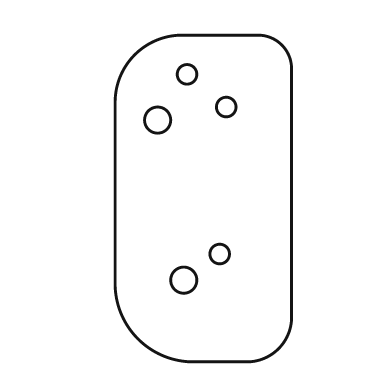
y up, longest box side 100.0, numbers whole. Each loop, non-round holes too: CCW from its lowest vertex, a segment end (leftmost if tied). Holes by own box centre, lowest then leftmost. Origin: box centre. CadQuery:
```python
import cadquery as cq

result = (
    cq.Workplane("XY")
    .moveTo(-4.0, -50.0)
    .lineTo(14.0, -50.0)
    .threePointArc((23.0, -46.0), (27.0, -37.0))
    .lineTo(27.0, 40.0)
    .threePointArc((24.0, 47.0), (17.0, 50.0))
    .lineTo(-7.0, 50.0)
    .threePointArc((-21.0, 44.0), (-27.0, 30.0))
    .lineTo(-27.0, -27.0)
    .threePointArc((-20.0, -43.0), (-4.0, -50.0))
    .close()
    .moveTo(-6.0, -25.0)
    .circle(4.0)
    .moveTo(5.0, -17.0)
    .circle(3.0)
    .moveTo(-14.0, 24.0)
    .circle(4.0)
    .moveTo(7.0, 28.0)
    .circle(3.0)
    .moveTo(-5.0, 38.0)
    .circle(3.0)
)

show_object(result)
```